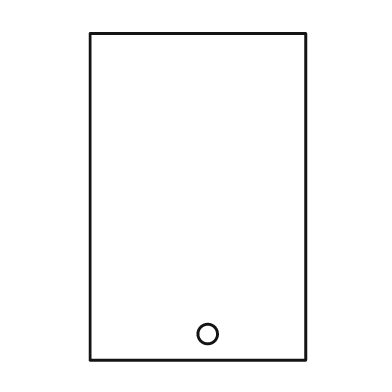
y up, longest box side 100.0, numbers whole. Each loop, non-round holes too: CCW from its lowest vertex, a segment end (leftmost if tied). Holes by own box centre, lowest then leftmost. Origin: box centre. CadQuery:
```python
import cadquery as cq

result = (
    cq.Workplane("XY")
    .moveTo(-33.0, -50.0)
    .lineTo(33.0, -50.0)
    .lineTo(33.0, 50.0)
    .lineTo(-33.0, 50.0)
    .close()
    .moveTo(3.0, -42.0)
    .circle(3.0)
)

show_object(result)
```